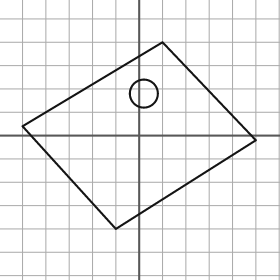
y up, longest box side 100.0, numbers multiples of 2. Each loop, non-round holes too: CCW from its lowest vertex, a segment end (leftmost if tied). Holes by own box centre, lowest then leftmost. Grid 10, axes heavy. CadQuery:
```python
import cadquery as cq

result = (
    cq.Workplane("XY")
    .moveTo(-10.0, -40.0)
    .lineTo(50.0, -2.0)
    .lineTo(10.0, 40.0)
    .lineTo(-50.0, 4.0)
    .close()
    .moveTo(2.0, 18.0)
    .circle(6.0)
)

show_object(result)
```